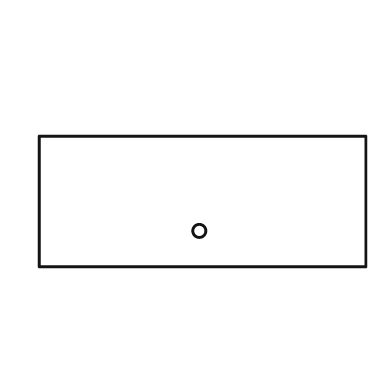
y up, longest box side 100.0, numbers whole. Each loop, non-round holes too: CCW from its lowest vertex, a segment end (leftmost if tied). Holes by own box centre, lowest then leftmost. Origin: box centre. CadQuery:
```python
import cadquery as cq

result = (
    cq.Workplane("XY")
    .moveTo(-50.0, -20.0)
    .lineTo(50.0, -20.0)
    .lineTo(50.0, 20.0)
    .lineTo(-50.0, 20.0)
    .close()
    .moveTo(-1.0, -9.0)
    .circle(2.0)
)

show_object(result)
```